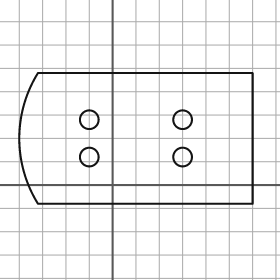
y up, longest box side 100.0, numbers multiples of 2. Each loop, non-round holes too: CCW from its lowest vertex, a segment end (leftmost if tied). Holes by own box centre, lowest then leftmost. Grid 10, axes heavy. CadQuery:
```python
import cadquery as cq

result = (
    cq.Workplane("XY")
    .moveTo(-32.0, -8.0)
    .lineTo(60.0, -8.0)
    .lineTo(60.0, 48.0)
    .lineTo(-32.0, 48.0)
    .threePointArc((-40.0, 20.0), (-32.0, -8.0))
    .close()
    .moveTo(-10.0, 12.0)
    .circle(4.0)
    .moveTo(30.0, 12.0)
    .circle(4.0)
    .moveTo(-10.0, 28.0)
    .circle(4.0)
    .moveTo(30.0, 28.0)
    .circle(4.0)
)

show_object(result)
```